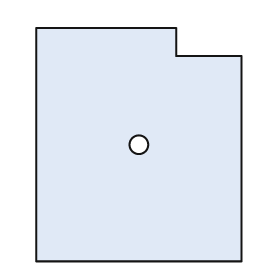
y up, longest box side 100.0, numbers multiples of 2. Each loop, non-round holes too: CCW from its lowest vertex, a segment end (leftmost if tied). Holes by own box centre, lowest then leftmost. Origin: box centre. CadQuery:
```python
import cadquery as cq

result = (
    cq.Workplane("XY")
    .moveTo(-44.0, -50.0)
    .lineTo(44.0, -50.0)
    .lineTo(44.0, 38.0)
    .lineTo(16.0, 38.0)
    .lineTo(16.0, 50.0)
    .lineTo(-44.0, 50.0)
    .close()
    .moveTo(0.0, 0.0)
    .circle(4.0)
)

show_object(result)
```